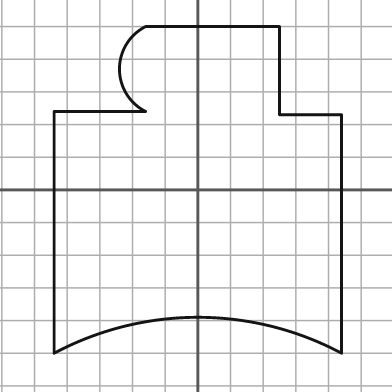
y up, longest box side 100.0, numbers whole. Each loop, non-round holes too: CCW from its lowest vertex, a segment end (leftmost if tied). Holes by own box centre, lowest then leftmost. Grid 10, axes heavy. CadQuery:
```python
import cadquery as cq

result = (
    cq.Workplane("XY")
    .moveTo(-44.0, -50.0)
    .threePointArc((0.0, -39.0), (44.0, -50.0))
    .lineTo(44.0, 23.0)
    .lineTo(25.0, 23.0)
    .lineTo(25.0, 50.0)
    .lineTo(-16.0, 50.0)
    .threePointArc((-24.0, 37.0), (-16.0, 24.0))
    .lineTo(-44.0, 24.0)
    .close()
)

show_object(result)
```